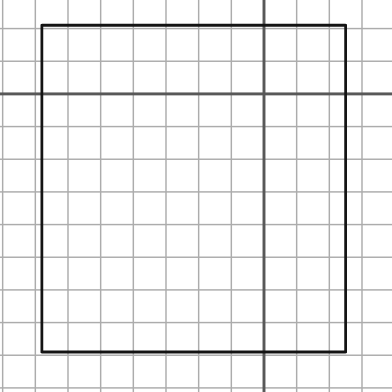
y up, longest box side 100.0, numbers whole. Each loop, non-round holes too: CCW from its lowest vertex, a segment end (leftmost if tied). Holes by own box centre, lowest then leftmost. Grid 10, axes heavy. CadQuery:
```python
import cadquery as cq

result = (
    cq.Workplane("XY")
    .moveTo(-68.0, -79.0)
    .lineTo(25.0, -79.0)
    .lineTo(25.0, 21.0)
    .lineTo(-68.0, 21.0)
    .close()
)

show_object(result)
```